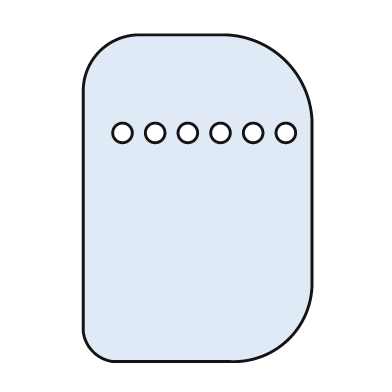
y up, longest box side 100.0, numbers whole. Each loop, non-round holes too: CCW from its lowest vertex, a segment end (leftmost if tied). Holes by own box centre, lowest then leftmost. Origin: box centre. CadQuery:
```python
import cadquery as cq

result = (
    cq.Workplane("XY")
    .moveTo(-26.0, -50.0)
    .lineTo(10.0, -50.0)
    .threePointArc((28.0, -43.0), (35.0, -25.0))
    .lineTo(35.0, 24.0)
    .threePointArc((27.0, 42.0), (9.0, 50.0))
    .lineTo(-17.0, 50.0)
    .threePointArc((-30.0, 45.0), (-35.0, 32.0))
    .lineTo(-35.0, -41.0)
    .threePointArc((-32.0, -47.0), (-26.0, -50.0))
    .close()
    .moveTo(-23.0, 20.0)
    .circle(3.0)
    .moveTo(-13.0, 20.0)
    .circle(3.0)
    .moveTo(-3.0, 20.0)
    .circle(3.0)
    .moveTo(7.0, 20.0)
    .circle(3.0)
    .moveTo(17.0, 20.0)
    .circle(3.0)
    .moveTo(27.0, 20.0)
    .circle(3.0)
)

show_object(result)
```